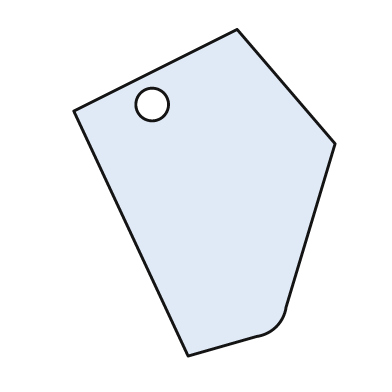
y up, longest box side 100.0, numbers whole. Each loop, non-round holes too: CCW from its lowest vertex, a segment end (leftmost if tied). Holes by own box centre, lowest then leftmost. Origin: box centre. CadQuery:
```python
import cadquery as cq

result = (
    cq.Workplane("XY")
    .moveTo(-5.0, -50.0)
    .lineTo(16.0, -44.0)
    .threePointArc((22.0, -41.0), (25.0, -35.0))
    .lineTo(40.0, 15.0)
    .lineTo(10.0, 50.0)
    .lineTo(-40.0, 25.0)
    .close()
    .moveTo(-16.0, 27.0)
    .circle(5.0)
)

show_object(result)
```